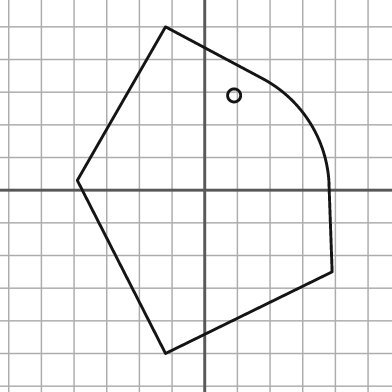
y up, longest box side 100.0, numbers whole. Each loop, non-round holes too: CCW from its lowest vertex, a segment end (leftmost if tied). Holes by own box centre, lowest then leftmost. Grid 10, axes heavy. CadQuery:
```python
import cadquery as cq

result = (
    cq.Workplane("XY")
    .moveTo(-12.0, -50.0)
    .lineTo(39.0, -25.0)
    .lineTo(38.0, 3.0)
    .threePointArc((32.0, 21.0), (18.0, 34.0))
    .lineTo(-12.0, 50.0)
    .lineTo(-39.0, 3.0)
    .close()
    .moveTo(9.0, 29.0)
    .circle(2.0)
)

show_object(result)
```